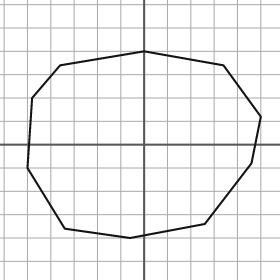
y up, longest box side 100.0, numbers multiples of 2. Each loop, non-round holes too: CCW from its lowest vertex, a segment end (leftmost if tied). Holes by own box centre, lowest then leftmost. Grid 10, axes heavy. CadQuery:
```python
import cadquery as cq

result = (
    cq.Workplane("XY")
    .moveTo(-6.0, -40.0)
    .lineTo(26.0, -34.0)
    .lineTo(46.0, -8.0)
    .lineTo(50.0, 12.0)
    .lineTo(34.0, 34.0)
    .lineTo(0.0, 40.0)
    .lineTo(-36.0, 34.0)
    .lineTo(-48.0, 20.0)
    .lineTo(-50.0, -10.0)
    .lineTo(-34.0, -36.0)
    .close()
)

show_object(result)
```